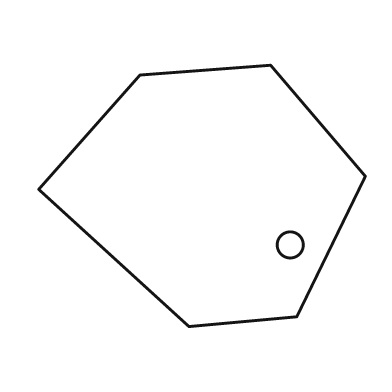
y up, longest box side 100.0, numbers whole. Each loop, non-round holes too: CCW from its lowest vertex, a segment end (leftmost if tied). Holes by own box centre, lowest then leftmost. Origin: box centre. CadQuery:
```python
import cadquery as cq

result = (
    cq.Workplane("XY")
    .moveTo(-4.0, -40.0)
    .lineTo(29.0, -37.0)
    .lineTo(50.0, 6.0)
    .lineTo(21.0, 40.0)
    .lineTo(-19.0, 37.0)
    .lineTo(-50.0, 2.0)
    .close()
    .moveTo(27.0, -15.0)
    .circle(4.0)
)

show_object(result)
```